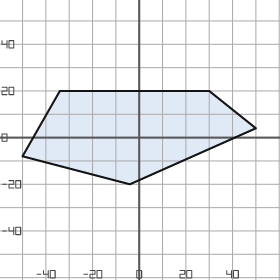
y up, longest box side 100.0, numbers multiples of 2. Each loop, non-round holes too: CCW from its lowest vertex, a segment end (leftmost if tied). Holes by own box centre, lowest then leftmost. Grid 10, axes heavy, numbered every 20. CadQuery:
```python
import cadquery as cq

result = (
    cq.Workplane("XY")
    .moveTo(-4.0, -20.0)
    .lineTo(50.0, 4.0)
    .lineTo(30.0, 20.0)
    .lineTo(-34.0, 20.0)
    .lineTo(-50.0, -8.0)
    .close()
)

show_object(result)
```